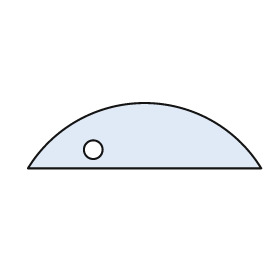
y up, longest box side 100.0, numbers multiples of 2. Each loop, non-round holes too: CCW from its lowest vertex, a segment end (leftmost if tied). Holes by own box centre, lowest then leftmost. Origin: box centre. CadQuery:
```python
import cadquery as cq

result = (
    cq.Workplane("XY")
    .moveTo(-50.0, -14.0)
    .lineTo(50.0, -14.0)
    .threePointArc((0.0, 14.0), (-50.0, -14.0))
    .close()
    .moveTo(-22.0, -6.0)
    .circle(4.0)
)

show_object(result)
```